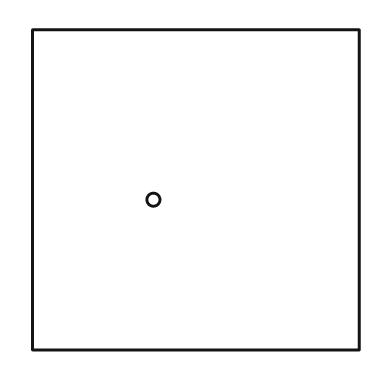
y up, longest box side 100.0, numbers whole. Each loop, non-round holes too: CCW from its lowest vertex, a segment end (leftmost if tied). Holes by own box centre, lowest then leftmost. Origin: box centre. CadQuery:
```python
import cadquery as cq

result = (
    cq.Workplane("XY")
    .moveTo(-50.0, -49.0)
    .lineTo(50.0, -49.0)
    .lineTo(50.0, 49.0)
    .lineTo(-50.0, 49.0)
    .close()
    .moveTo(-13.0, -3.0)
    .circle(2.0)
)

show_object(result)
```